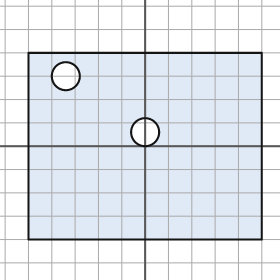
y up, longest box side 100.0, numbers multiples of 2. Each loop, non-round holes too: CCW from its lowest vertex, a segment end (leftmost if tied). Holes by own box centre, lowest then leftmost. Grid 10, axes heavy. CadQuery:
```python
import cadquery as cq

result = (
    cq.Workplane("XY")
    .moveTo(-50.0, -40.0)
    .lineTo(50.0, -40.0)
    .lineTo(50.0, 40.0)
    .lineTo(-50.0, 40.0)
    .close()
    .moveTo(0.0, 6.0)
    .circle(6.0)
    .moveTo(-34.0, 30.0)
    .circle(6.0)
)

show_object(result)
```